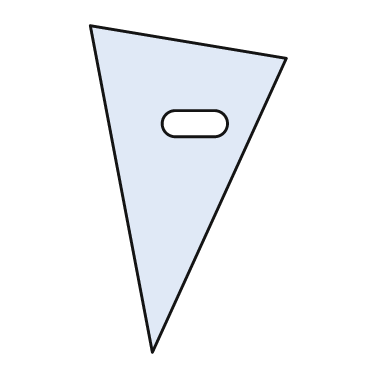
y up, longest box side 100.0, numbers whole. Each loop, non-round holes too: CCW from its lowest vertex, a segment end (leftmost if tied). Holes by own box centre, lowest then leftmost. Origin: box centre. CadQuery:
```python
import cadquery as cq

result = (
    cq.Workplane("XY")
    .moveTo(-11.0, -50.0)
    .lineTo(30.0, 40.0)
    .lineTo(-30.0, 50.0)
    .close()
    .moveTo(-4.0, 16.0)
    .lineTo(8.0, 16.0)
    .threePointArc((12.0, 20.0), (8.0, 24.0))
    .lineTo(-4.0, 24.0)
    .threePointArc((-8.0, 20.0), (-4.0, 16.0))
    .close()
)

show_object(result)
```